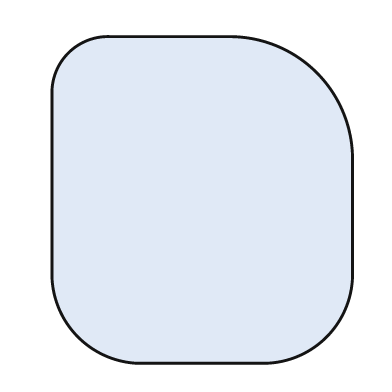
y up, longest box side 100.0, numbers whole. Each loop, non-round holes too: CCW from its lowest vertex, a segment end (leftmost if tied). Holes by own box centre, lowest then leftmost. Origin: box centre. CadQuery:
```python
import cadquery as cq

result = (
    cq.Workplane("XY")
    .moveTo(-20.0, -50.0)
    .lineTo(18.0, -50.0)
    .threePointArc((38.0, -42.0), (46.0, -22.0))
    .lineTo(46.0, 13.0)
    .threePointArc((35.0, 39.0), (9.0, 50.0))
    .lineTo(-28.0, 50.0)
    .threePointArc((-41.0, 45.0), (-46.0, 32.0))
    .lineTo(-46.0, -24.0)
    .threePointArc((-38.0, -42.0), (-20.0, -50.0))
    .close()
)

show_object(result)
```